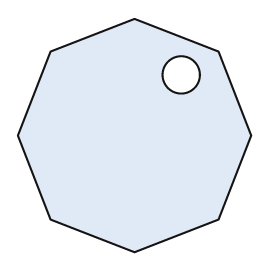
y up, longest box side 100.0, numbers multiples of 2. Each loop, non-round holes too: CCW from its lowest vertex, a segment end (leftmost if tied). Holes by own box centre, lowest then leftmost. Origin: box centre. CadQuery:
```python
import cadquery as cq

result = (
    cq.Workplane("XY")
    .moveTo(0.0, -50.0)
    .lineTo(36.0, -36.0)
    .lineTo(50.0, 0.0)
    .lineTo(36.0, 36.0)
    .lineTo(0.0, 50.0)
    .lineTo(-36.0, 36.0)
    .lineTo(-50.0, 0.0)
    .lineTo(-36.0, -36.0)
    .close()
    .moveTo(20.0, 26.0)
    .circle(8.0)
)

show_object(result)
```